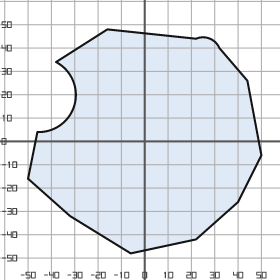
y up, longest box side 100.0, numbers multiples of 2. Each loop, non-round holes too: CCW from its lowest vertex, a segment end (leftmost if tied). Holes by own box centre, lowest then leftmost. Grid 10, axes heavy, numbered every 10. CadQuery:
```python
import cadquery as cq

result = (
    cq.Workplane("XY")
    .moveTo(-6.0, -48.0)
    .lineTo(22.0, -42.0)
    .lineTo(40.0, -26.0)
    .lineTo(50.0, -6.0)
    .lineTo(44.0, 26.0)
    .lineTo(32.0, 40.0)
    .threePointArc((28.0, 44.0), (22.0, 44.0))
    .lineTo(-16.0, 48.0)
    .lineTo(-38.0, 34.0)
    .threePointArc((-30.0, 16.0), (-46.0, 4.0))
    .lineTo(-50.0, -16.0)
    .lineTo(-32.0, -32.0)
    .close()
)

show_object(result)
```